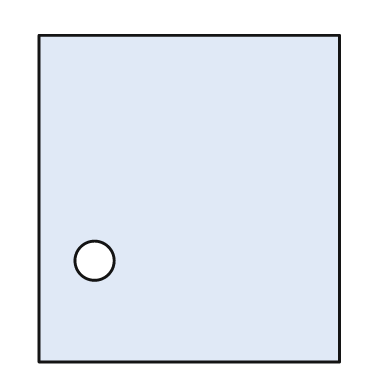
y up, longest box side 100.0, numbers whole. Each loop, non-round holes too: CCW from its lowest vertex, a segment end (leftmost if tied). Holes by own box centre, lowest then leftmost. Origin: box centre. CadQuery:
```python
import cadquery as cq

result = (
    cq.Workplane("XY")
    .moveTo(-46.0, -50.0)
    .lineTo(46.0, -50.0)
    .lineTo(46.0, 50.0)
    .lineTo(-46.0, 50.0)
    .close()
    .moveTo(-29.0, -19.0)
    .circle(6.0)
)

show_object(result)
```